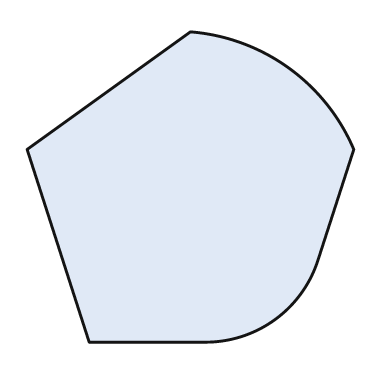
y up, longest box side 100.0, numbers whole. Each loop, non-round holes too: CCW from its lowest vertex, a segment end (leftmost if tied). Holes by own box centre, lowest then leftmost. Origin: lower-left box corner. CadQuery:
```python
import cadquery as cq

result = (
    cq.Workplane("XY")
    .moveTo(19.0, 0.0)
    .lineTo(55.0, 0.0)
    .threePointArc((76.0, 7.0), (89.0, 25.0))
    .lineTo(100.0, 59.0)
    .threePointArc((80.0, 84.0), (50.0, 95.0))
    .lineTo(0.0, 59.0)
    .close()
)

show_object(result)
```